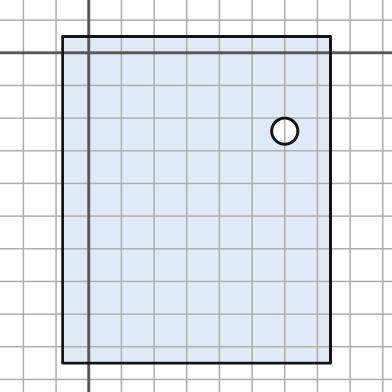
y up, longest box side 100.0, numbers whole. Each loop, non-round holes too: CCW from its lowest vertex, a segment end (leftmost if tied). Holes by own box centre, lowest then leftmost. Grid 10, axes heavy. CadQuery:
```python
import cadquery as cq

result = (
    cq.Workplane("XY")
    .moveTo(-8.0, -95.0)
    .lineTo(74.0, -95.0)
    .lineTo(74.0, 5.0)
    .lineTo(-8.0, 5.0)
    .close()
    .moveTo(60.0, -24.0)
    .circle(4.0)
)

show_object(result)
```